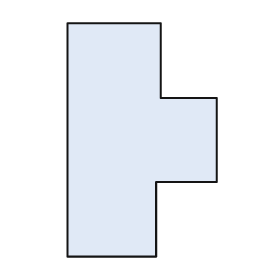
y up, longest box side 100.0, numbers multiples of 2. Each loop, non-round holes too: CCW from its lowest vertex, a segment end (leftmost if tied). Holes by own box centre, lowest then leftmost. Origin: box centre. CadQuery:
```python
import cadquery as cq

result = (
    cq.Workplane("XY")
    .moveTo(-32.0, -50.0)
    .lineTo(6.0, -50.0)
    .lineTo(6.0, -18.0)
    .lineTo(32.0, -18.0)
    .lineTo(32.0, 18.0)
    .lineTo(8.0, 18.0)
    .lineTo(8.0, 50.0)
    .lineTo(-32.0, 50.0)
    .close()
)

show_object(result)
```